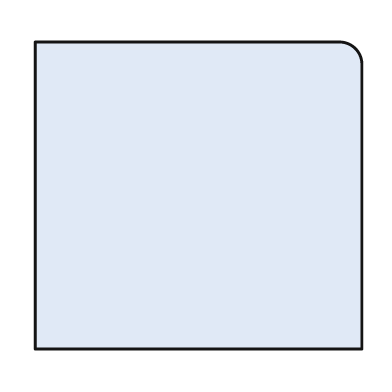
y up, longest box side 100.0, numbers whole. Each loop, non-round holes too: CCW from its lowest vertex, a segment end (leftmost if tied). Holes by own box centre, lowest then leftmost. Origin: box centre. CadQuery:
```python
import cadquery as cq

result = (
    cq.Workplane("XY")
    .moveTo(-50.0, -47.0)
    .lineTo(50.0, -47.0)
    .lineTo(50.0, 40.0)
    .threePointArc((48.0, 45.0), (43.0, 47.0))
    .lineTo(-50.0, 47.0)
    .close()
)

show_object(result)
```